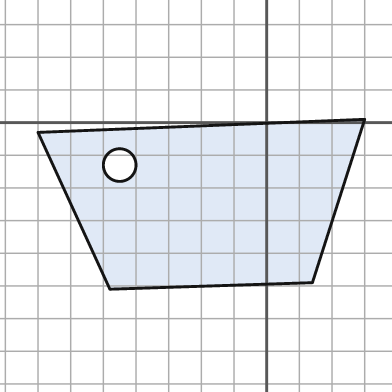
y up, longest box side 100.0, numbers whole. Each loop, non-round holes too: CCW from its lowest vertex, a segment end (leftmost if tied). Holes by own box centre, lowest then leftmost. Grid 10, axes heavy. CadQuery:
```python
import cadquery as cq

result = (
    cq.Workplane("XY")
    .moveTo(-48.0, -51.0)
    .lineTo(14.0, -49.0)
    .lineTo(30.0, 1.0)
    .lineTo(-70.0, -3.0)
    .close()
    .moveTo(-45.0, -13.0)
    .circle(5.0)
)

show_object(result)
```